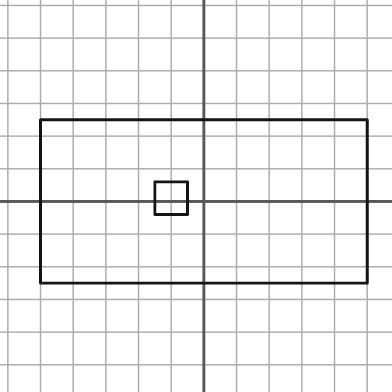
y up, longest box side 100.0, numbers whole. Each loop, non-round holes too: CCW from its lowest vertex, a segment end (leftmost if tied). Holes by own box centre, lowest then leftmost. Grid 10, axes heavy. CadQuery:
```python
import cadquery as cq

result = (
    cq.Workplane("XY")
    .moveTo(-50.0, -25.0)
    .lineTo(50.0, -25.0)
    .lineTo(50.0, 25.0)
    .lineTo(-50.0, 25.0)
    .close()
    .moveTo(-15.0, -4.0)
    .lineTo(-5.0, -4.0)
    .lineTo(-5.0, 6.0)
    .lineTo(-15.0, 6.0)
    .close()
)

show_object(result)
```